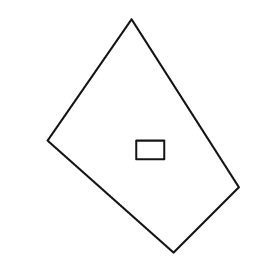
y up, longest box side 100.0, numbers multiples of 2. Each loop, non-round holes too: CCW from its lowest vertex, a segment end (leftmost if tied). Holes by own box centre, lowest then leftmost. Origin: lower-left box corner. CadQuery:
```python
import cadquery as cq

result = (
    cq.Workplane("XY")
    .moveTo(54.0, 0.0)
    .lineTo(82.0, 28.0)
    .lineTo(36.0, 100.0)
    .lineTo(0.0, 48.0)
    .close()
    .moveTo(38.0, 40.0)
    .lineTo(50.0, 40.0)
    .lineTo(50.0, 48.0)
    .lineTo(38.0, 48.0)
    .close()
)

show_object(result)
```